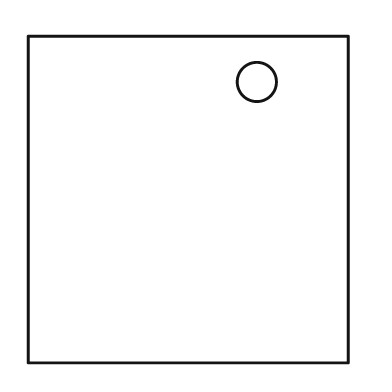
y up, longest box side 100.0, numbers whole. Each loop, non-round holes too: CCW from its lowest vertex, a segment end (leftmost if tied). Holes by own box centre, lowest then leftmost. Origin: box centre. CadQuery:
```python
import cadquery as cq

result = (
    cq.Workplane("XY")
    .moveTo(-49.0, -50.0)
    .lineTo(49.0, -50.0)
    .lineTo(49.0, 50.0)
    .lineTo(-49.0, 50.0)
    .close()
    .moveTo(21.0, 36.0)
    .circle(6.0)
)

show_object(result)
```